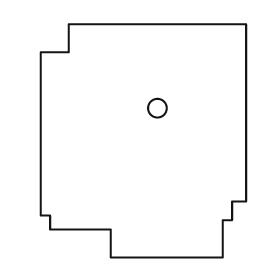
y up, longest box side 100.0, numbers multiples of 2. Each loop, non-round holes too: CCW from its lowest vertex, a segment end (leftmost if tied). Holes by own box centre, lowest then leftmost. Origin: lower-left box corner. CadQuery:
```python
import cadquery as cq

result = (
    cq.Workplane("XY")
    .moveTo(30.0, 0.0)
    .lineTo(78.0, 0.0)
    .lineTo(78.0, 16.0)
    .lineTo(82.0, 16.0)
    .lineTo(82.0, 24.0)
    .lineTo(88.0, 24.0)
    .lineTo(88.0, 100.0)
    .lineTo(12.0, 100.0)
    .lineTo(12.0, 88.0)
    .lineTo(0.0, 88.0)
    .lineTo(0.0, 18.0)
    .lineTo(4.0, 18.0)
    .lineTo(4.0, 12.0)
    .lineTo(30.0, 12.0)
    .close()
    .moveTo(50.0, 64.0)
    .circle(4.0)
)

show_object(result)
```